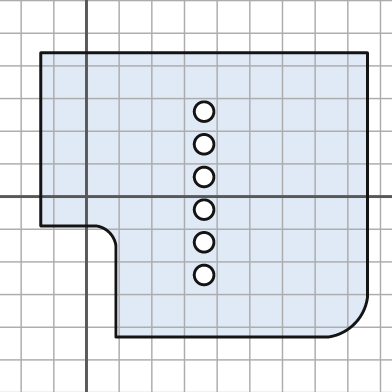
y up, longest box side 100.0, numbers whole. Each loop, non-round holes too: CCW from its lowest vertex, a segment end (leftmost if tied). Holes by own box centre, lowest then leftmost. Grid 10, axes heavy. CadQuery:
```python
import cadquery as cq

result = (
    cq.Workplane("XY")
    .moveTo(9.0, -43.0)
    .lineTo(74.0, -43.0)
    .threePointArc((82.0, -39.0), (86.0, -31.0))
    .lineTo(86.0, 44.0)
    .lineTo(-14.0, 44.0)
    .lineTo(-14.0, -9.0)
    .lineTo(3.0, -9.0)
    .threePointArc((7.0, -11.0), (9.0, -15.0))
    .close()
    .moveTo(36.0, -24.0)
    .circle(3.0)
    .moveTo(36.0, -14.0)
    .circle(3.0)
    .moveTo(36.0, -4.0)
    .circle(3.0)
    .moveTo(36.0, 6.0)
    .circle(3.0)
    .moveTo(36.0, 16.0)
    .circle(3.0)
    .moveTo(36.0, 26.0)
    .circle(3.0)
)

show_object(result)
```